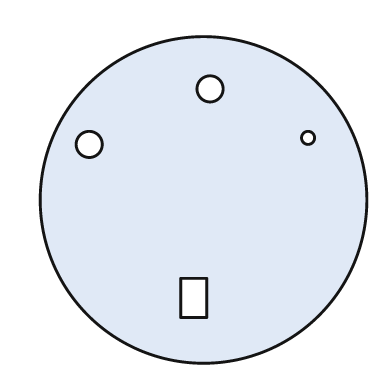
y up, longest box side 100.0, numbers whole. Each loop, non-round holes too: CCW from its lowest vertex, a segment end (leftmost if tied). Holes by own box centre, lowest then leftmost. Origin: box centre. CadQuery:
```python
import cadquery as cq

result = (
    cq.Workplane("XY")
    .moveTo(0.0, 0.0)
    .circle(50.0)
    .moveTo(-7.0, -36.0)
    .lineTo(1.0, -36.0)
    .lineTo(1.0, -24.0)
    .lineTo(-7.0, -24.0)
    .close()
    .moveTo(-35.0, 17.0)
    .circle(4.0)
    .moveTo(32.0, 19.0)
    .circle(2.0)
    .moveTo(2.0, 34.0)
    .circle(4.0)
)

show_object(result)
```